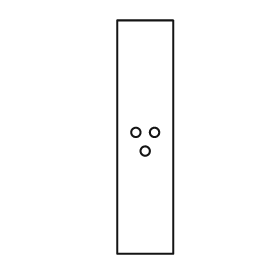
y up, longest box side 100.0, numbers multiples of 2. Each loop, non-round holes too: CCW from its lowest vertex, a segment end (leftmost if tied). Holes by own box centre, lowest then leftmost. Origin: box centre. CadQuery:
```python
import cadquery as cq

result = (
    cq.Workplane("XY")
    .moveTo(-12.0, -50.0)
    .lineTo(12.0, -50.0)
    .lineTo(12.0, 50.0)
    .lineTo(-12.0, 50.0)
    .close()
    .moveTo(0.0, -6.0)
    .circle(2.0)
    .moveTo(-4.0, 2.0)
    .circle(2.0)
    .moveTo(4.0, 2.0)
    .circle(2.0)
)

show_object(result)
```